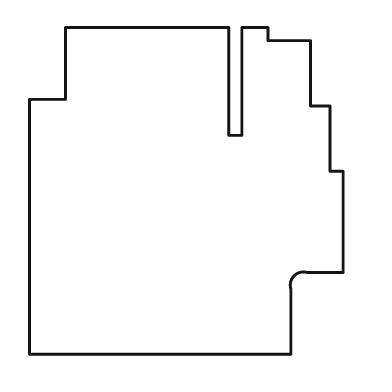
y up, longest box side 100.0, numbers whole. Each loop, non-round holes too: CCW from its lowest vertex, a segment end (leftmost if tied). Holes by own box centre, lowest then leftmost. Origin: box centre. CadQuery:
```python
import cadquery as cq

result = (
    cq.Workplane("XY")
    .moveTo(-48.0, -50.0)
    .lineTo(32.0, -50.0)
    .lineTo(32.0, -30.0)
    .threePointArc((33.0, -26.0), (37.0, -25.0))
    .lineTo(48.0, -25.0)
    .lineTo(48.0, 6.0)
    .lineTo(44.0, 6.0)
    .lineTo(44.0, 26.0)
    .lineTo(38.0, 26.0)
    .lineTo(38.0, 46.0)
    .lineTo(25.0, 46.0)
    .lineTo(25.0, 50.0)
    .lineTo(17.0, 50.0)
    .lineTo(17.0, 17.0)
    .lineTo(13.0, 17.0)
    .lineTo(13.0, 50.0)
    .lineTo(-37.0, 50.0)
    .lineTo(-37.0, 28.0)
    .lineTo(-48.0, 28.0)
    .close()
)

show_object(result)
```